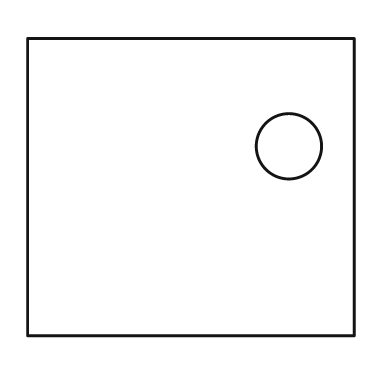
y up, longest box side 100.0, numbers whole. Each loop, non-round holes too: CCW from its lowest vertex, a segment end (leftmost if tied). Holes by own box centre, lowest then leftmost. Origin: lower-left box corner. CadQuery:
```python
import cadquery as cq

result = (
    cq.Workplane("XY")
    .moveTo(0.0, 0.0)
    .lineTo(100.0, 0.0)
    .lineTo(100.0, 91.0)
    .lineTo(0.0, 91.0)
    .close()
    .moveTo(80.0, 58.0)
    .circle(10.0)
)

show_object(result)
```